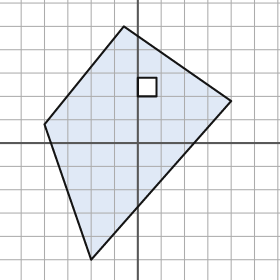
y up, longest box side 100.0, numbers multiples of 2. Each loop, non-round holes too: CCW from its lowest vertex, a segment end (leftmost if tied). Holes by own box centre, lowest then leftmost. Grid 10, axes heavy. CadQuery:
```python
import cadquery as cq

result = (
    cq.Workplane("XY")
    .moveTo(-20.0, -50.0)
    .lineTo(40.0, 18.0)
    .lineTo(-6.0, 50.0)
    .lineTo(-40.0, 8.0)
    .close()
    .moveTo(0.0, 20.0)
    .lineTo(8.0, 20.0)
    .lineTo(8.0, 28.0)
    .lineTo(0.0, 28.0)
    .close()
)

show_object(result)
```